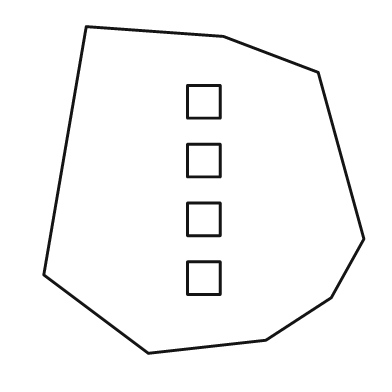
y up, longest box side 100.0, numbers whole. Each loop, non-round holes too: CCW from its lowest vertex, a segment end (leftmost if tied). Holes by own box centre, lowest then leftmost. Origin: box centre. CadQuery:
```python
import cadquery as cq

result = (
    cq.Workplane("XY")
    .moveTo(-17.0, -50.0)
    .lineTo(19.0, -46.0)
    .lineTo(39.0, -33.0)
    .lineTo(49.0, -15.0)
    .lineTo(35.0, 36.0)
    .lineTo(6.0, 47.0)
    .lineTo(-36.0, 50.0)
    .lineTo(-49.0, -26.0)
    .close()
    .moveTo(-5.0, -32.0)
    .lineTo(5.0, -32.0)
    .lineTo(5.0, -22.0)
    .lineTo(-5.0, -22.0)
    .close()
    .moveTo(-5.0, -14.0)
    .lineTo(5.0, -14.0)
    .lineTo(5.0, -4.0)
    .lineTo(-5.0, -4.0)
    .close()
    .moveTo(-5.0, 4.0)
    .lineTo(5.0, 4.0)
    .lineTo(5.0, 14.0)
    .lineTo(-5.0, 14.0)
    .close()
    .moveTo(-5.0, 22.0)
    .lineTo(5.0, 22.0)
    .lineTo(5.0, 32.0)
    .lineTo(-5.0, 32.0)
    .close()
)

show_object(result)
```